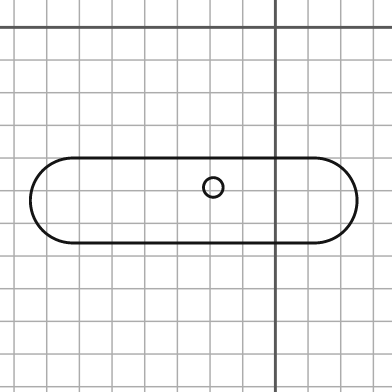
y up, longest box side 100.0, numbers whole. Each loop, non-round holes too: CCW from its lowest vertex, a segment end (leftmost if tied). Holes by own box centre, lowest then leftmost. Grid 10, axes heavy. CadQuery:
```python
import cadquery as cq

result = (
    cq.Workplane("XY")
    .moveTo(-62.0, -66.0)
    .lineTo(12.0, -66.0)
    .threePointArc((25.0, -53.0), (12.0, -40.0))
    .lineTo(-62.0, -40.0)
    .threePointArc((-75.0, -53.0), (-62.0, -66.0))
    .close()
    .moveTo(-19.0, -49.0)
    .circle(3.0)
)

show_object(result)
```